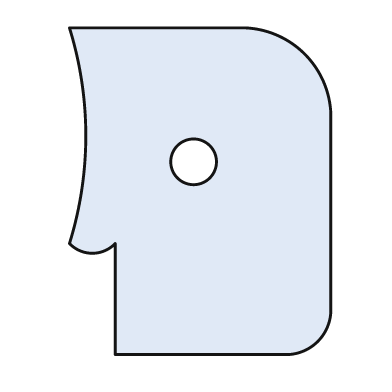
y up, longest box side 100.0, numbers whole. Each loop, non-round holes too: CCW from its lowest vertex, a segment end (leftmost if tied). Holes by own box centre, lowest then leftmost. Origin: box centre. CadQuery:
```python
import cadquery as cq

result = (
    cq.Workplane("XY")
    .moveTo(-26.0, -50.0)
    .lineTo(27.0, -50.0)
    .threePointArc((36.0, -46.0), (40.0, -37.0))
    .lineTo(40.0, 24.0)
    .threePointArc((32.0, 42.0), (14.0, 50.0))
    .lineTo(-40.0, 50.0)
    .threePointArc((-35.0, 17.0), (-40.0, -16.0))
    .threePointArc((-33.0, -19.0), (-26.0, -16.0))
    .close()
    .moveTo(-2.0, 9.0)
    .circle(7.0)
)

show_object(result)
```